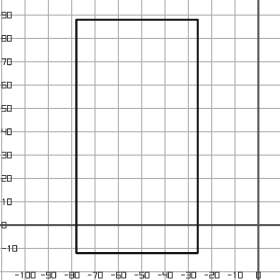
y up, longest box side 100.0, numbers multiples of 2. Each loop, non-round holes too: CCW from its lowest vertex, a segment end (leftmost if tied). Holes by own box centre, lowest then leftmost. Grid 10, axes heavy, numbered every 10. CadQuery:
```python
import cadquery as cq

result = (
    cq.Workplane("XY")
    .moveTo(-78.0, -12.0)
    .lineTo(-26.0, -12.0)
    .lineTo(-26.0, 88.0)
    .lineTo(-78.0, 88.0)
    .close()
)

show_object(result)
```